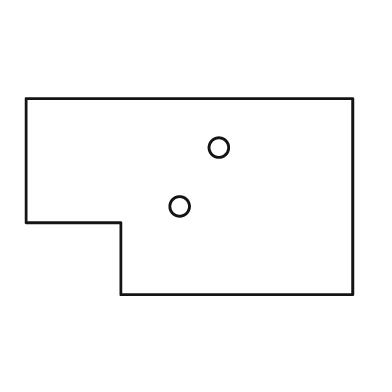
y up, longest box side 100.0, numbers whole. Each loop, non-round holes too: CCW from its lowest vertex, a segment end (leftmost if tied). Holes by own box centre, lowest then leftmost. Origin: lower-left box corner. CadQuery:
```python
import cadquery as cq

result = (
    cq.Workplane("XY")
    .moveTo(29.0, 0.0)
    .lineTo(100.0, 0.0)
    .lineTo(100.0, 60.0)
    .lineTo(0.0, 60.0)
    .lineTo(0.0, 22.0)
    .lineTo(29.0, 22.0)
    .close()
    .moveTo(47.0, 27.0)
    .circle(3.0)
    .moveTo(59.0, 45.0)
    .circle(3.0)
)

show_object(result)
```